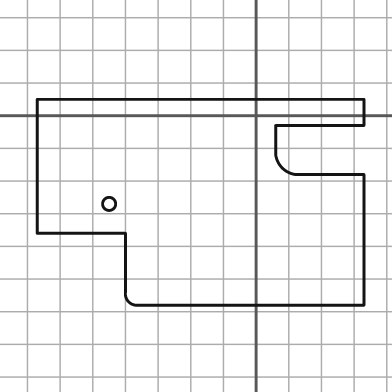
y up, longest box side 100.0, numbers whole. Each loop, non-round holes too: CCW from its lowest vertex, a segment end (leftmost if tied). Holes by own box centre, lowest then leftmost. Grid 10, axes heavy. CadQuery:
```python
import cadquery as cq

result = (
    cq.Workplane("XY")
    .moveTo(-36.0, -58.0)
    .lineTo(33.0, -58.0)
    .lineTo(33.0, -18.0)
    .lineTo(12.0, -18.0)
    .threePointArc((8.0, -16.0), (6.0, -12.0))
    .lineTo(6.0, -3.0)
    .lineTo(33.0, -3.0)
    .lineTo(33.0, 5.0)
    .lineTo(-67.0, 5.0)
    .lineTo(-67.0, -36.0)
    .lineTo(-40.0, -36.0)
    .lineTo(-40.0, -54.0)
    .threePointArc((-39.0, -57.0), (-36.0, -58.0))
    .close()
    .moveTo(-45.0, -27.0)
    .circle(2.0)
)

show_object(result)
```